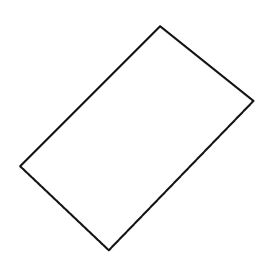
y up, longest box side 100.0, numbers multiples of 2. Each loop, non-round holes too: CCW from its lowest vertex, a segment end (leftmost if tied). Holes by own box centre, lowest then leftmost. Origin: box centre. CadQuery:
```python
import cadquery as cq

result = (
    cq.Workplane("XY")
    .moveTo(-12.0, -48.0)
    .lineTo(50.0, 16.0)
    .lineTo(10.0, 48.0)
    .lineTo(-50.0, -12.0)
    .close()
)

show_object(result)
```